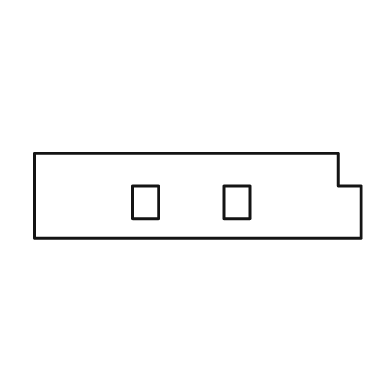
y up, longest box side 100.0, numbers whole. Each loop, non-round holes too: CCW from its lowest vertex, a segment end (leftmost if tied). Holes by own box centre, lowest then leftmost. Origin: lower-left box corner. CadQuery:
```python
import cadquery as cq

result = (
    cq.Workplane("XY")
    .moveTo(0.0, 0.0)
    .lineTo(100.0, 0.0)
    .lineTo(100.0, 16.0)
    .lineTo(93.0, 16.0)
    .lineTo(93.0, 26.0)
    .lineTo(0.0, 26.0)
    .close()
    .moveTo(30.0, 6.0)
    .lineTo(38.0, 6.0)
    .lineTo(38.0, 16.0)
    .lineTo(30.0, 16.0)
    .close()
    .moveTo(58.0, 6.0)
    .lineTo(66.0, 6.0)
    .lineTo(66.0, 16.0)
    .lineTo(58.0, 16.0)
    .close()
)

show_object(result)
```